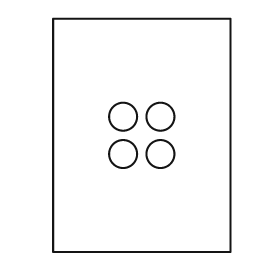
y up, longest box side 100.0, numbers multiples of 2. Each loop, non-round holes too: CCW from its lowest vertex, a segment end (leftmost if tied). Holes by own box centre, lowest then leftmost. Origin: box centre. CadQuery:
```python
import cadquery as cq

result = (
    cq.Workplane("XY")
    .moveTo(-38.0, -50.0)
    .lineTo(38.0, -50.0)
    .lineTo(38.0, 50.0)
    .lineTo(-38.0, 50.0)
    .close()
    .moveTo(-8.0, -8.0)
    .circle(6.0)
    .moveTo(8.0, -8.0)
    .circle(6.0)
    .moveTo(-8.0, 8.0)
    .circle(6.0)
    .moveTo(8.0, 8.0)
    .circle(6.0)
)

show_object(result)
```